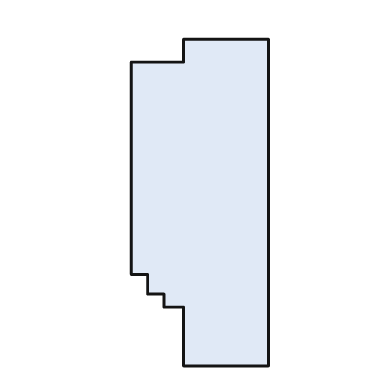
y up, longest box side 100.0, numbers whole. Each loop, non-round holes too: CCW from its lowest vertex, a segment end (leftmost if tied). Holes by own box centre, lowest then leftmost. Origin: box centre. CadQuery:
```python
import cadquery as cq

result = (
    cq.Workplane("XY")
    .moveTo(-5.0, -50.0)
    .lineTo(21.0, -50.0)
    .lineTo(21.0, 50.0)
    .lineTo(-5.0, 50.0)
    .lineTo(-5.0, 43.0)
    .lineTo(-21.0, 43.0)
    .lineTo(-21.0, -22.0)
    .lineTo(-16.0, -22.0)
    .lineTo(-16.0, -28.0)
    .lineTo(-11.0, -28.0)
    .lineTo(-11.0, -32.0)
    .lineTo(-5.0, -32.0)
    .close()
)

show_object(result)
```